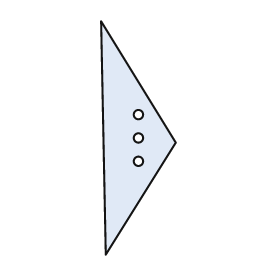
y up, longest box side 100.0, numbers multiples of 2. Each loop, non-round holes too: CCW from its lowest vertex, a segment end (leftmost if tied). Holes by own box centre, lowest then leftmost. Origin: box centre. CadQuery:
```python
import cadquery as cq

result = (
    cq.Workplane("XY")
    .moveTo(-14.0, -50.0)
    .lineTo(16.0, -2.0)
    .lineTo(-16.0, 50.0)
    .close()
    .moveTo(0.0, -10.0)
    .circle(2.0)
    .moveTo(0.0, 0.0)
    .circle(2.0)
    .moveTo(0.0, 10.0)
    .circle(2.0)
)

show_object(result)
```